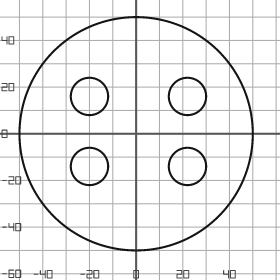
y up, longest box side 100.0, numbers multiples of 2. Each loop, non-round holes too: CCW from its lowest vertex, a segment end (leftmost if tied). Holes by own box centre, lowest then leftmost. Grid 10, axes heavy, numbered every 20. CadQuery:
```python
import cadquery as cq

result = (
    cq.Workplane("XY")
    .moveTo(0.0, 0.0)
    .circle(50.0)
    .moveTo(-20.0, -14.0)
    .circle(8.0)
    .moveTo(22.0, -14.0)
    .circle(8.0)
    .moveTo(-20.0, 16.0)
    .circle(8.0)
    .moveTo(22.0, 16.0)
    .circle(8.0)
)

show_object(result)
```